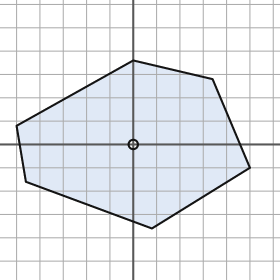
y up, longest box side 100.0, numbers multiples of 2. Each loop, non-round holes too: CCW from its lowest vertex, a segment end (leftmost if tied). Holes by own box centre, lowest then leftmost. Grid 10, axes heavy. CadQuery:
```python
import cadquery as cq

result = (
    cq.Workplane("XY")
    .moveTo(8.0, -36.0)
    .lineTo(50.0, -10.0)
    .lineTo(34.0, 28.0)
    .lineTo(0.0, 36.0)
    .lineTo(-50.0, 8.0)
    .lineTo(-46.0, -16.0)
    .close()
    .moveTo(0.0, 0.0)
    .circle(2.0)
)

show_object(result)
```